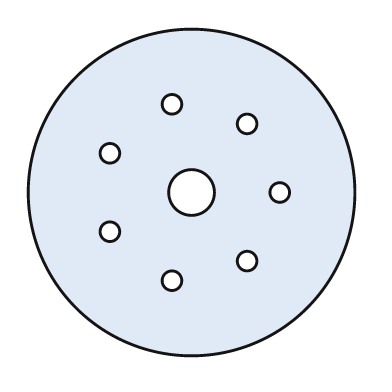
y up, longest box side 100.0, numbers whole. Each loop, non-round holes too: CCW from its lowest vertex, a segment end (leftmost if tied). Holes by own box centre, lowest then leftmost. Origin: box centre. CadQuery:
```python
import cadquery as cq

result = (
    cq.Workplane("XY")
    .moveTo(0.0, 0.0)
    .circle(50.0)
    .moveTo(-6.0, -27.0)
    .circle(3.0)
    .moveTo(17.0, -21.0)
    .circle(3.0)
    .moveTo(-25.0, -12.0)
    .circle(3.0)
    .moveTo(0.0, 0.0)
    .circle(7.0)
    .moveTo(27.0, 0.0)
    .circle(3.0)
    .moveTo(-25.0, 12.0)
    .circle(3.0)
    .moveTo(17.0, 21.0)
    .circle(3.0)
    .moveTo(-6.0, 27.0)
    .circle(3.0)
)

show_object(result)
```